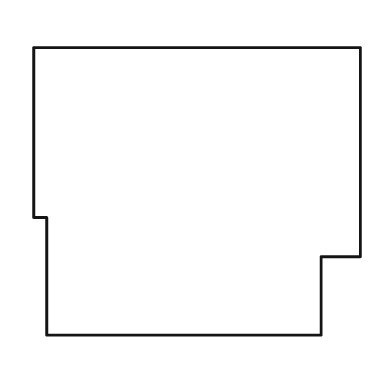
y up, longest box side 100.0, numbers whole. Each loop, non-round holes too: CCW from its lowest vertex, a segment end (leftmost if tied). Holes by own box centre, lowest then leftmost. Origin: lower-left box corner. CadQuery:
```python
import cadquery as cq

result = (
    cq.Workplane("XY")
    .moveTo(4.0, 0.0)
    .lineTo(88.0, 0.0)
    .lineTo(88.0, 24.0)
    .lineTo(100.0, 24.0)
    .lineTo(100.0, 88.0)
    .lineTo(0.0, 88.0)
    .lineTo(0.0, 36.0)
    .lineTo(4.0, 36.0)
    .close()
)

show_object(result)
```